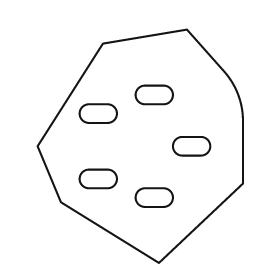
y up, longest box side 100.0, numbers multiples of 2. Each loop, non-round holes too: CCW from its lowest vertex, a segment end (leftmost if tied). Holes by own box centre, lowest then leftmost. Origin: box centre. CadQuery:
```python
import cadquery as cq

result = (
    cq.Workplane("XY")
    .moveTo(8.0, -50.0)
    .lineTo(44.0, -16.0)
    .lineTo(44.0, 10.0)
    .threePointArc((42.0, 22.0), (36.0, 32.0))
    .lineTo(20.0, 50.0)
    .lineTo(-16.0, 44.0)
    .lineTo(-44.0, 0.0)
    .lineTo(-34.0, -24.0)
    .close()
    .moveTo(2.0, -26.0)
    .lineTo(10.0, -26.0)
    .threePointArc((14.0, -22.0), (10.0, -18.0))
    .lineTo(2.0, -18.0)
    .threePointArc((-2.0, -22.0), (2.0, -26.0))
    .close()
    .moveTo(-22.0, -18.0)
    .lineTo(-14.0, -18.0)
    .threePointArc((-10.0, -14.0), (-14.0, -10.0))
    .lineTo(-22.0, -10.0)
    .threePointArc((-26.0, -14.0), (-22.0, -18.0))
    .close()
    .moveTo(18.0, -4.0)
    .lineTo(26.0, -4.0)
    .threePointArc((30.0, 0.0), (26.0, 4.0))
    .lineTo(18.0, 4.0)
    .threePointArc((14.0, 0.0), (18.0, -4.0))
    .close()
    .moveTo(-22.0, 10.0)
    .lineTo(-14.0, 10.0)
    .threePointArc((-10.0, 14.0), (-14.0, 18.0))
    .lineTo(-22.0, 18.0)
    .threePointArc((-26.0, 14.0), (-22.0, 10.0))
    .close()
    .moveTo(2.0, 18.0)
    .lineTo(10.0, 18.0)
    .threePointArc((14.0, 22.0), (10.0, 26.0))
    .lineTo(2.0, 26.0)
    .threePointArc((-2.0, 22.0), (2.0, 18.0))
    .close()
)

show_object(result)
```